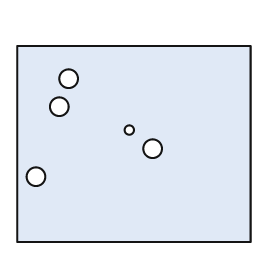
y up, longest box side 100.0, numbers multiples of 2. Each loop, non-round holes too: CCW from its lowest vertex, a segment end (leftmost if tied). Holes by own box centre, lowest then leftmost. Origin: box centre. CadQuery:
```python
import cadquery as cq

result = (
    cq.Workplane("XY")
    .moveTo(-50.0, -42.0)
    .lineTo(50.0, -42.0)
    .lineTo(50.0, 42.0)
    .lineTo(-50.0, 42.0)
    .close()
    .moveTo(-42.0, -14.0)
    .circle(4.0)
    .moveTo(8.0, -2.0)
    .circle(4.0)
    .moveTo(-2.0, 6.0)
    .circle(2.0)
    .moveTo(-32.0, 16.0)
    .circle(4.0)
    .moveTo(-28.0, 28.0)
    .circle(4.0)
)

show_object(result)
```